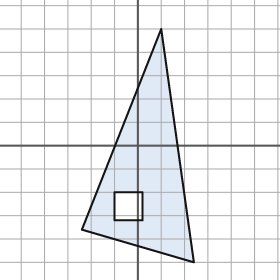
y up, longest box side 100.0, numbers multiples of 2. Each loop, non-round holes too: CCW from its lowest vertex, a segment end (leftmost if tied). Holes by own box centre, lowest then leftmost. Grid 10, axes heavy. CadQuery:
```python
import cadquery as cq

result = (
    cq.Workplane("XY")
    .moveTo(24.0, -50.0)
    .lineTo(10.0, 50.0)
    .lineTo(-24.0, -36.0)
    .close()
    .moveTo(-10.0, -32.0)
    .lineTo(2.0, -32.0)
    .lineTo(2.0, -20.0)
    .lineTo(-10.0, -20.0)
    .close()
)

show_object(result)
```